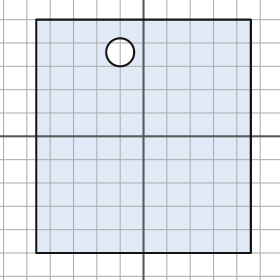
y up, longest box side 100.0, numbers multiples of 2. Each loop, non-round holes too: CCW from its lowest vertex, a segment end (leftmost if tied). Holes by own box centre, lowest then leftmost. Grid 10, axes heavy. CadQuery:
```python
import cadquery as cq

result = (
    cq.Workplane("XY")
    .moveTo(-46.0, -50.0)
    .lineTo(46.0, -50.0)
    .lineTo(46.0, 50.0)
    .lineTo(-46.0, 50.0)
    .close()
    .moveTo(-10.0, 36.0)
    .circle(6.0)
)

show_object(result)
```